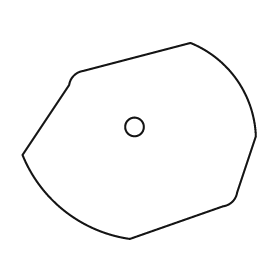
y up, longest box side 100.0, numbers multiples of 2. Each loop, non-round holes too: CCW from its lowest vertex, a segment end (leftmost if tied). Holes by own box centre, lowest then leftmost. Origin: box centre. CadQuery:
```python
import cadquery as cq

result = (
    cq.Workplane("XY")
    .moveTo(-4.0, -42.0)
    .lineTo(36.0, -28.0)
    .threePointArc((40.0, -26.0), (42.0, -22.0))
    .lineTo(50.0, 2.0)
    .threePointArc((42.0, 26.0), (22.0, 42.0))
    .lineTo(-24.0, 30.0)
    .threePointArc((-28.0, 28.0), (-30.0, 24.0))
    .lineTo(-50.0, -6.0)
    .threePointArc((-32.0, -30.0), (-4.0, -42.0))
    .close()
    .moveTo(-2.0, 6.0)
    .circle(4.0)
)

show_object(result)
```